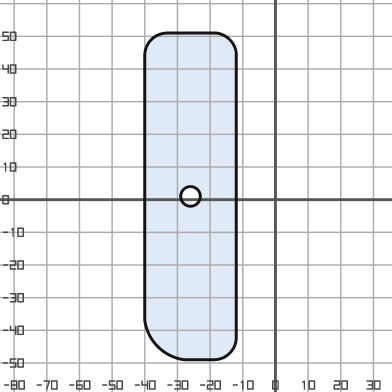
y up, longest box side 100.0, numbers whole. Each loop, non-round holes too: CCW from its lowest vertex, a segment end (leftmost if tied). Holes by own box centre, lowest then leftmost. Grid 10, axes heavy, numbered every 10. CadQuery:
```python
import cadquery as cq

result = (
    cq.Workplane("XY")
    .moveTo(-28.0, -49.0)
    .lineTo(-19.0, -49.0)
    .threePointArc((-14.0, -47.0), (-12.0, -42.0))
    .lineTo(-12.0, 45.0)
    .threePointArc((-14.0, 49.0), (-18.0, 51.0))
    .lineTo(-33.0, 51.0)
    .threePointArc((-38.0, 49.0), (-40.0, 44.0))
    .lineTo(-40.0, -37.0)
    .threePointArc((-36.0, -45.0), (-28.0, -49.0))
    .close()
    .moveTo(-26.0, 1.0)
    .circle(3.0)
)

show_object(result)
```